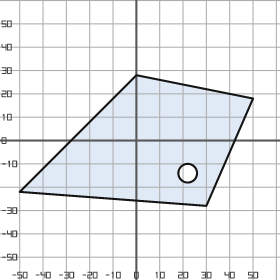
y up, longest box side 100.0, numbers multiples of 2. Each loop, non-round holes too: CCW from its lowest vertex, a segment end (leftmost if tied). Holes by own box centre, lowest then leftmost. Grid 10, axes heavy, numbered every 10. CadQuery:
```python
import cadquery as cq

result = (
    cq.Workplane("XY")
    .moveTo(30.0, -28.0)
    .lineTo(50.0, 18.0)
    .lineTo(0.0, 28.0)
    .lineTo(-50.0, -22.0)
    .close()
    .moveTo(22.0, -14.0)
    .circle(4.0)
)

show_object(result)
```